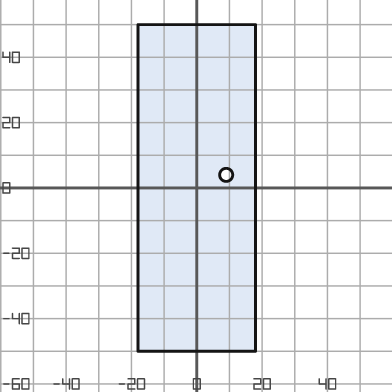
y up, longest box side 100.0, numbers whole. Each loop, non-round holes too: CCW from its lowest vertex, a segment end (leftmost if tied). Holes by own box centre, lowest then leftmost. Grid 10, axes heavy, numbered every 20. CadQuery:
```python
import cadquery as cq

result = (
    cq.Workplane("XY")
    .moveTo(-18.0, -50.0)
    .lineTo(18.0, -50.0)
    .lineTo(18.0, 50.0)
    .lineTo(-18.0, 50.0)
    .close()
    .moveTo(9.0, 4.0)
    .circle(2.0)
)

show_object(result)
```